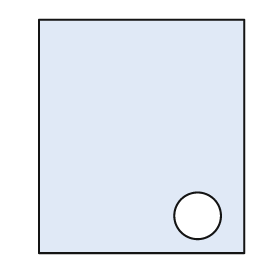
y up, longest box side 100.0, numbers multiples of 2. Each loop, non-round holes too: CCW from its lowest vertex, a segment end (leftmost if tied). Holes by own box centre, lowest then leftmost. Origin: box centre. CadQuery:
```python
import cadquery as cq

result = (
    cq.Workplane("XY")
    .moveTo(-44.0, -50.0)
    .lineTo(44.0, -50.0)
    .lineTo(44.0, 50.0)
    .lineTo(-44.0, 50.0)
    .close()
    .moveTo(24.0, -34.0)
    .circle(10.0)
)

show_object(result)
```